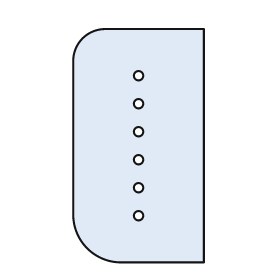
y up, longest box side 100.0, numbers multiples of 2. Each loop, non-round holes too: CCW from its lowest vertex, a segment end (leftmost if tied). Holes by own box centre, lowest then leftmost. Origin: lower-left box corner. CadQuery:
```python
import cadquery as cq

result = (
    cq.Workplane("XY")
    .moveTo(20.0, 0.0)
    .lineTo(56.0, 0.0)
    .lineTo(56.0, 100.0)
    .lineTo(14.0, 100.0)
    .threePointArc((4.0, 96.0), (0.0, 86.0))
    .lineTo(0.0, 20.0)
    .threePointArc((6.0, 6.0), (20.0, 0.0))
    .close()
    .moveTo(28.0, 20.0)
    .circle(2.0)
    .moveTo(28.0, 32.0)
    .circle(2.0)
    .moveTo(28.0, 44.0)
    .circle(2.0)
    .moveTo(28.0, 56.0)
    .circle(2.0)
    .moveTo(28.0, 68.0)
    .circle(2.0)
    .moveTo(28.0, 80.0)
    .circle(2.0)
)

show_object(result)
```